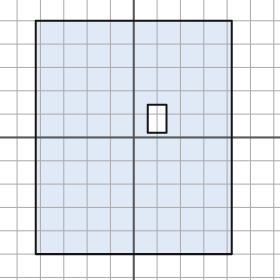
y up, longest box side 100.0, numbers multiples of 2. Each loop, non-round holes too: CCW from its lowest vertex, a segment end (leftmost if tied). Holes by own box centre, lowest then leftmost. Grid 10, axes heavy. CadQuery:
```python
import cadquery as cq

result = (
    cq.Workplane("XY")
    .moveTo(-42.0, -50.0)
    .lineTo(42.0, -50.0)
    .lineTo(42.0, 50.0)
    .lineTo(-42.0, 50.0)
    .close()
    .moveTo(6.0, 2.0)
    .lineTo(14.0, 2.0)
    .lineTo(14.0, 14.0)
    .lineTo(6.0, 14.0)
    .close()
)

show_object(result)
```